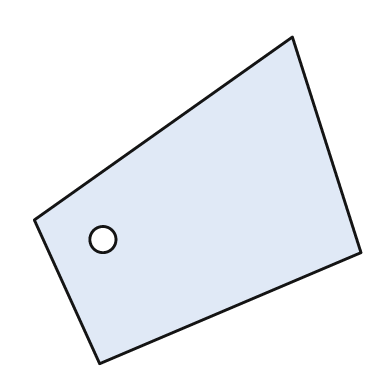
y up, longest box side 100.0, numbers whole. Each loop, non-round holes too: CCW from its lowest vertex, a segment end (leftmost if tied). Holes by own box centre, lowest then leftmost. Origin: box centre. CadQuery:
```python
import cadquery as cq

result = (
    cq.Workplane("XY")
    .moveTo(-30.0, -50.0)
    .lineTo(50.0, -16.0)
    .lineTo(29.0, 50.0)
    .lineTo(-50.0, -6.0)
    .close()
    .moveTo(-29.0, -12.0)
    .circle(4.0)
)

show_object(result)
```